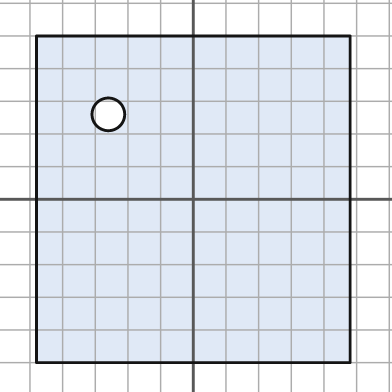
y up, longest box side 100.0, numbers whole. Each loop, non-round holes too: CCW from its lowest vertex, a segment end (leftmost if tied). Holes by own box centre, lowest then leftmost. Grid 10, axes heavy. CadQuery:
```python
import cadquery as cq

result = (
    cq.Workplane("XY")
    .moveTo(-48.0, -50.0)
    .lineTo(48.0, -50.0)
    .lineTo(48.0, 50.0)
    .lineTo(-48.0, 50.0)
    .close()
    .moveTo(-26.0, 26.0)
    .circle(5.0)
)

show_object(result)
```